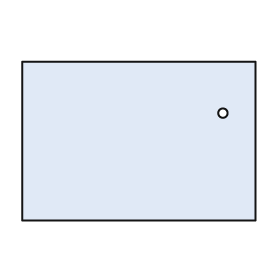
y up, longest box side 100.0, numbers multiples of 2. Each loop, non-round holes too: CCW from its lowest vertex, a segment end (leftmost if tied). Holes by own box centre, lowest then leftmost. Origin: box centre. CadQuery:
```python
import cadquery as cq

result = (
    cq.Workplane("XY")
    .moveTo(-50.0, -34.0)
    .lineTo(50.0, -34.0)
    .lineTo(50.0, 34.0)
    .lineTo(-50.0, 34.0)
    .close()
    .moveTo(36.0, 12.0)
    .circle(2.0)
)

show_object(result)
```